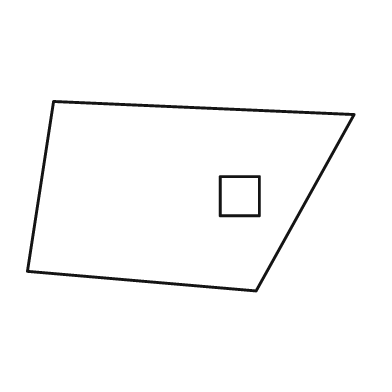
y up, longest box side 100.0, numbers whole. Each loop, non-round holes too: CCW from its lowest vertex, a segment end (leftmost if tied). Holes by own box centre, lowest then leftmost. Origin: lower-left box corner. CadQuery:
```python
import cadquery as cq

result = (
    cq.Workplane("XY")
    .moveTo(70.0, 0.0)
    .lineTo(100.0, 54.0)
    .lineTo(8.0, 58.0)
    .lineTo(0.0, 6.0)
    .close()
    .moveTo(59.0, 23.0)
    .lineTo(71.0, 23.0)
    .lineTo(71.0, 35.0)
    .lineTo(59.0, 35.0)
    .close()
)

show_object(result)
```